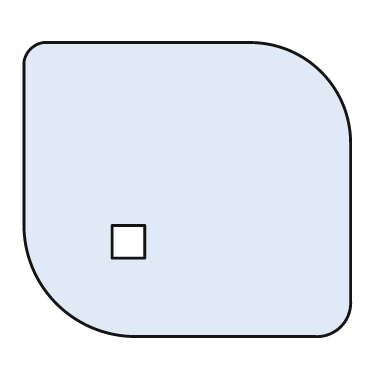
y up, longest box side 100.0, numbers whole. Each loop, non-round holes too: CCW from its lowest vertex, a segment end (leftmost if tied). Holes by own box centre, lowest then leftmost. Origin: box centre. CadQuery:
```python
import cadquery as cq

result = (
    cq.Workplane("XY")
    .moveTo(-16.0, -45.0)
    .lineTo(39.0, -45.0)
    .threePointArc((47.0, -42.0), (50.0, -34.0))
    .lineTo(50.0, 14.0)
    .threePointArc((41.0, 36.0), (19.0, 45.0))
    .lineTo(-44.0, 45.0)
    .threePointArc((-48.0, 43.0), (-50.0, 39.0))
    .lineTo(-50.0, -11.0)
    .threePointArc((-40.0, -35.0), (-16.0, -45.0))
    .close()
    .moveTo(-23.0, -21.0)
    .lineTo(-13.0, -21.0)
    .lineTo(-13.0, -11.0)
    .lineTo(-23.0, -11.0)
    .close()
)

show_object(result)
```